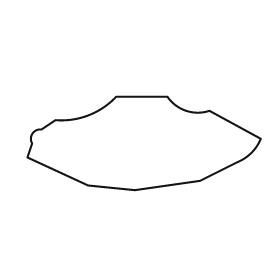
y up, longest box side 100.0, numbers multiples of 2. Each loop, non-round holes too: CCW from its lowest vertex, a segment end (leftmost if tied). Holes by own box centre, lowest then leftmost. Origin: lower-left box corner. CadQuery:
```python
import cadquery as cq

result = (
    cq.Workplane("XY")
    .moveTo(46.0, 0.0)
    .lineTo(74.0, 4.0)
    .lineTo(90.0, 12.0)
    .threePointArc((96.0, 16.0), (100.0, 22.0))
    .lineTo(78.0, 34.0)
    .threePointArc((68.0, 34.0), (60.0, 40.0))
    .lineTo(38.0, 40.0)
    .threePointArc((26.0, 32.0), (12.0, 30.0))
    .lineTo(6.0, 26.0)
    .threePointArc((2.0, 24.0), (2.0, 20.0))
    .lineTo(0.0, 14.0)
    .lineTo(26.0, 2.0)
    .close()
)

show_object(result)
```